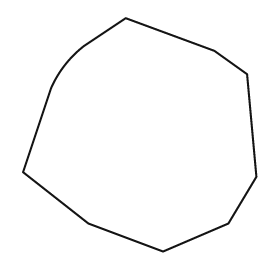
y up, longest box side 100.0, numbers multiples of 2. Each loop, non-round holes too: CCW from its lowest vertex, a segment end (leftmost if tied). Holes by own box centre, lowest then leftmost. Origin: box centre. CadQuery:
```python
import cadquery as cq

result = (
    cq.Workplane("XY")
    .moveTo(10.0, -50.0)
    .lineTo(38.0, -38.0)
    .lineTo(50.0, -18.0)
    .lineTo(46.0, 26.0)
    .lineTo(32.0, 36.0)
    .lineTo(-6.0, 50.0)
    .lineTo(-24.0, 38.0)
    .threePointArc((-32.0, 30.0), (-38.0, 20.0))
    .lineTo(-50.0, -16.0)
    .lineTo(-22.0, -38.0)
    .close()
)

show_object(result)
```